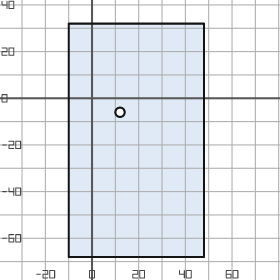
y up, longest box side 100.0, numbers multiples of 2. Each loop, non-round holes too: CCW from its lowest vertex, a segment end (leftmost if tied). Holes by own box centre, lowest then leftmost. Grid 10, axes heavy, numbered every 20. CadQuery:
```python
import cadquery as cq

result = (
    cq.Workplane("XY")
    .moveTo(-10.0, -68.0)
    .lineTo(48.0, -68.0)
    .lineTo(48.0, 32.0)
    .lineTo(-10.0, 32.0)
    .close()
    .moveTo(12.0, -6.0)
    .circle(2.0)
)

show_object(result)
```